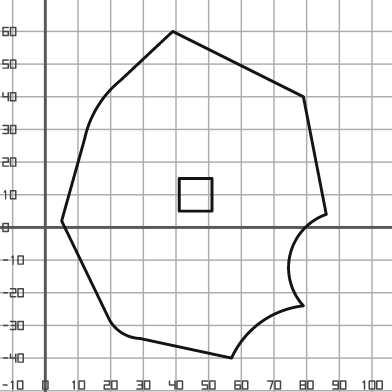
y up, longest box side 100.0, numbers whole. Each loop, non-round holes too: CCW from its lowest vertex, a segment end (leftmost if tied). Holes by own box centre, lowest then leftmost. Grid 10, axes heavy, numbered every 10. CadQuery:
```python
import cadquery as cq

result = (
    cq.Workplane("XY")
    .moveTo(57.0, -40.0)
    .threePointArc((66.0, -29.0), (79.0, -24.0))
    .threePointArc((75.0, -8.0), (86.0, 4.0))
    .lineTo(79.0, 40.0)
    .lineTo(39.0, 60.0)
    .lineTo(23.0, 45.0)
    .threePointArc((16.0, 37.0), (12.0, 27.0))
    .lineTo(5.0, 2.0)
    .lineTo(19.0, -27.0)
    .threePointArc((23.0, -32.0), (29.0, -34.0))
    .close()
    .moveTo(41.0, 5.0)
    .lineTo(51.0, 5.0)
    .lineTo(51.0, 15.0)
    .lineTo(41.0, 15.0)
    .close()
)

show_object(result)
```